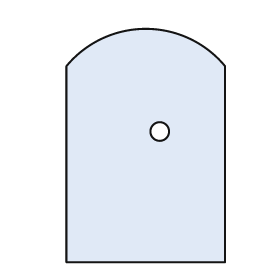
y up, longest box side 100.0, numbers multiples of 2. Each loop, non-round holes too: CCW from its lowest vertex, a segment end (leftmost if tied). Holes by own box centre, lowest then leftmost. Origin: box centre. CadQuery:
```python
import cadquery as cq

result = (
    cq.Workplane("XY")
    .moveTo(-34.0, -50.0)
    .lineTo(34.0, -50.0)
    .lineTo(34.0, 34.0)
    .threePointArc((0.0, 50.0), (-34.0, 34.0))
    .close()
    .moveTo(6.0, 6.0)
    .circle(4.0)
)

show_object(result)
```